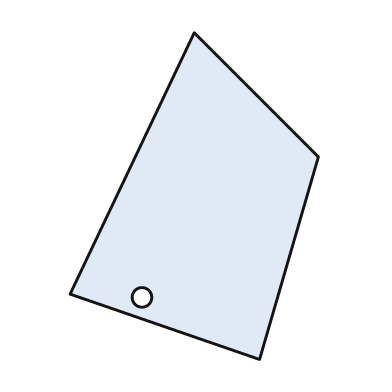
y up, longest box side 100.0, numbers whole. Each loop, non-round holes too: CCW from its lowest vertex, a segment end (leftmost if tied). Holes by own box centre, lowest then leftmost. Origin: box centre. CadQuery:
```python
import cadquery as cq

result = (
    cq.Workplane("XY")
    .moveTo(20.0, -50.0)
    .lineTo(38.0, 12.0)
    .lineTo(0.0, 50.0)
    .lineTo(-38.0, -30.0)
    .close()
    .moveTo(-16.0, -31.0)
    .circle(3.0)
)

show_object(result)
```